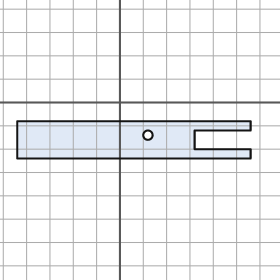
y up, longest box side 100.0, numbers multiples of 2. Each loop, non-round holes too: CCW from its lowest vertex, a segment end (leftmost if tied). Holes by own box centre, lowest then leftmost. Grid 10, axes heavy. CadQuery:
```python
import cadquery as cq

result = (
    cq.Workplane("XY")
    .moveTo(-44.0, -24.0)
    .lineTo(56.0, -24.0)
    .lineTo(56.0, -20.0)
    .lineTo(32.0, -20.0)
    .lineTo(32.0, -12.0)
    .lineTo(56.0, -12.0)
    .lineTo(56.0, -8.0)
    .lineTo(-44.0, -8.0)
    .close()
    .moveTo(12.0, -14.0)
    .circle(2.0)
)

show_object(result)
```